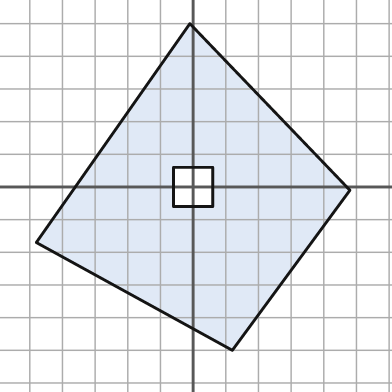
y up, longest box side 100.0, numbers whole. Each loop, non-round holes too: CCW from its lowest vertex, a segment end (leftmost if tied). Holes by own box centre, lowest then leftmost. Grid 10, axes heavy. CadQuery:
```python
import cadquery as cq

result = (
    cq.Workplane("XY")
    .moveTo(12.0, -50.0)
    .lineTo(48.0, -1.0)
    .lineTo(-1.0, 50.0)
    .lineTo(-48.0, -17.0)
    .close()
    .moveTo(-6.0, -6.0)
    .lineTo(6.0, -6.0)
    .lineTo(6.0, 6.0)
    .lineTo(-6.0, 6.0)
    .close()
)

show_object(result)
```